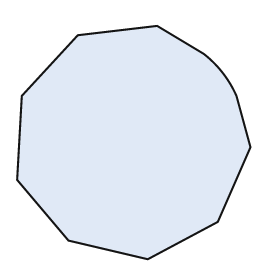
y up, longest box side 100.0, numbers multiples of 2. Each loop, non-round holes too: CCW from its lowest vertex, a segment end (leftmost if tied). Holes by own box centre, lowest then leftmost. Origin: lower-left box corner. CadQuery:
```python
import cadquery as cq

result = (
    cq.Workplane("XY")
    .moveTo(56.0, 0.0)
    .lineTo(86.0, 16.0)
    .lineTo(100.0, 48.0)
    .lineTo(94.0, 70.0)
    .threePointArc((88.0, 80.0), (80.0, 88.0))
    .lineTo(60.0, 100.0)
    .lineTo(26.0, 96.0)
    .lineTo(2.0, 70.0)
    .lineTo(0.0, 34.0)
    .lineTo(22.0, 8.0)
    .close()
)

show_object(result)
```